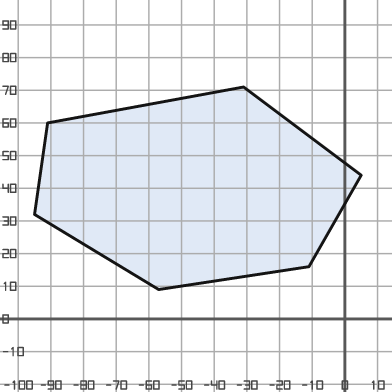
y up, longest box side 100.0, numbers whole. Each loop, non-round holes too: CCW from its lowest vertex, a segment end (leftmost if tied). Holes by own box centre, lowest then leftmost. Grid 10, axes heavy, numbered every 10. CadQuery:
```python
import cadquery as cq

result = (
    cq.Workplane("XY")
    .moveTo(-57.0, 9.0)
    .lineTo(-11.0, 16.0)
    .lineTo(5.0, 44.0)
    .lineTo(-31.0, 71.0)
    .lineTo(-91.0, 60.0)
    .lineTo(-95.0, 32.0)
    .close()
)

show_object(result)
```